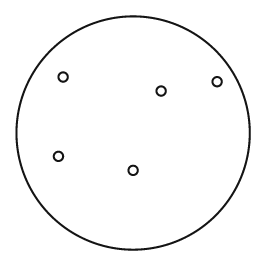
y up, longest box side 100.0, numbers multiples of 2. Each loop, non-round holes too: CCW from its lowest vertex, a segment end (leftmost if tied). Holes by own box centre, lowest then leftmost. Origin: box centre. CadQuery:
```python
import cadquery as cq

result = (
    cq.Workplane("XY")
    .moveTo(0.0, 0.0)
    .circle(50.0)
    .moveTo(0.0, -16.0)
    .circle(2.0)
    .moveTo(-32.0, -10.0)
    .circle(2.0)
    .moveTo(12.0, 18.0)
    .circle(2.0)
    .moveTo(36.0, 22.0)
    .circle(2.0)
    .moveTo(-30.0, 24.0)
    .circle(2.0)
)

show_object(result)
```